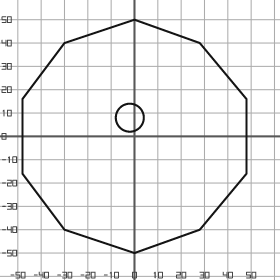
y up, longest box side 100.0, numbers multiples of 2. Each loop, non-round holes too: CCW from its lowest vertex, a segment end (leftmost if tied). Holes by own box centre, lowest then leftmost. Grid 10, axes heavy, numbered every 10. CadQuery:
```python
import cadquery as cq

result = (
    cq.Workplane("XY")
    .moveTo(0.0, -50.0)
    .lineTo(28.0, -40.0)
    .lineTo(48.0, -16.0)
    .lineTo(48.0, 16.0)
    .lineTo(28.0, 40.0)
    .lineTo(0.0, 50.0)
    .lineTo(-30.0, 40.0)
    .lineTo(-48.0, 16.0)
    .lineTo(-48.0, -16.0)
    .lineTo(-30.0, -40.0)
    .close()
    .moveTo(-2.0, 8.0)
    .circle(6.0)
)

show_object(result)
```